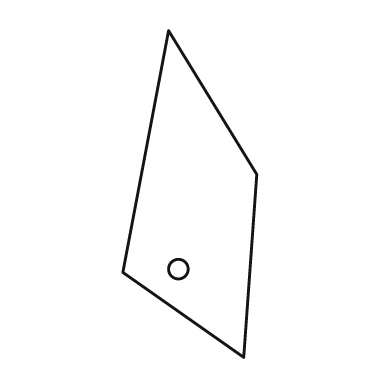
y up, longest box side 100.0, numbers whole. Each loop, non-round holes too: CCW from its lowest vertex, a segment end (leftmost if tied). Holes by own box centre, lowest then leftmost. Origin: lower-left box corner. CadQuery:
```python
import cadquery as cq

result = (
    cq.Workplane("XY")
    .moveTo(37.0, 0.0)
    .lineTo(41.0, 56.0)
    .lineTo(14.0, 100.0)
    .lineTo(0.0, 26.0)
    .close()
    .moveTo(17.0, 27.0)
    .circle(3.0)
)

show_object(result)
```